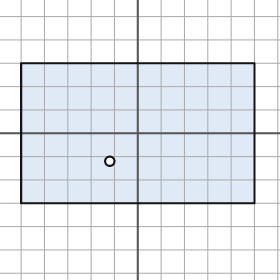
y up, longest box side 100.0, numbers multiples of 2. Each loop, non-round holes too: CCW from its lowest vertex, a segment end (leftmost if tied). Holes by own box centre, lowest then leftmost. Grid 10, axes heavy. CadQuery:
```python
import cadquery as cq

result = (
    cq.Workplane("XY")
    .moveTo(-50.0, -30.0)
    .lineTo(50.0, -30.0)
    .lineTo(50.0, 30.0)
    .lineTo(-50.0, 30.0)
    .close()
    .moveTo(-12.0, -12.0)
    .circle(2.0)
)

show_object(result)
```